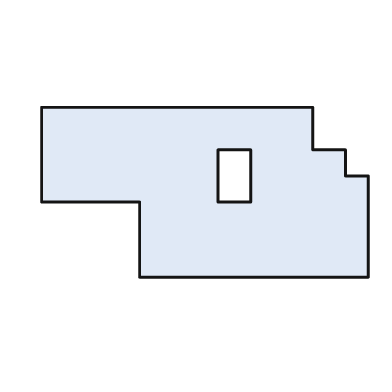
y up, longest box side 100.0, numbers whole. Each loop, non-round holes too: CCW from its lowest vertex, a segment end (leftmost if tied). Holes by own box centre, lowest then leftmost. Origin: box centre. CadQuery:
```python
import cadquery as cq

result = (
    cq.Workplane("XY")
    .moveTo(-20.0, -26.0)
    .lineTo(50.0, -26.0)
    .lineTo(50.0, 5.0)
    .lineTo(43.0, 5.0)
    .lineTo(43.0, 13.0)
    .lineTo(33.0, 13.0)
    .lineTo(33.0, 26.0)
    .lineTo(-50.0, 26.0)
    .lineTo(-50.0, -3.0)
    .lineTo(-20.0, -3.0)
    .close()
    .moveTo(4.0, -3.0)
    .lineTo(14.0, -3.0)
    .lineTo(14.0, 13.0)
    .lineTo(4.0, 13.0)
    .close()
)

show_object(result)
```